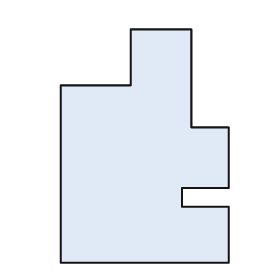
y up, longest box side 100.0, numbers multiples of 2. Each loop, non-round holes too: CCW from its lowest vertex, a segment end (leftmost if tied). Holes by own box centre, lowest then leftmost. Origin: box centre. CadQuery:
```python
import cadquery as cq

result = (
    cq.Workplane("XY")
    .moveTo(-36.0, -50.0)
    .lineTo(36.0, -50.0)
    .lineTo(36.0, -26.0)
    .lineTo(16.0, -26.0)
    .lineTo(16.0, -18.0)
    .lineTo(36.0, -18.0)
    .lineTo(36.0, 8.0)
    .lineTo(20.0, 8.0)
    .lineTo(20.0, 50.0)
    .lineTo(-6.0, 50.0)
    .lineTo(-6.0, 26.0)
    .lineTo(-36.0, 26.0)
    .close()
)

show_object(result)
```